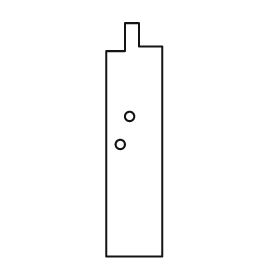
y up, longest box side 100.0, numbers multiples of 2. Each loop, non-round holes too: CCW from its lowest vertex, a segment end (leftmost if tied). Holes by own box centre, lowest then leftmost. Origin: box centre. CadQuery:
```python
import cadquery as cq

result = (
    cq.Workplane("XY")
    .moveTo(-12.0, -50.0)
    .lineTo(12.0, -50.0)
    .lineTo(12.0, 40.0)
    .lineTo(2.0, 40.0)
    .lineTo(2.0, 50.0)
    .lineTo(-4.0, 50.0)
    .lineTo(-4.0, 38.0)
    .lineTo(-12.0, 38.0)
    .close()
    .moveTo(-6.0, -2.0)
    .circle(2.0)
    .moveTo(-2.0, 10.0)
    .circle(2.0)
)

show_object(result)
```